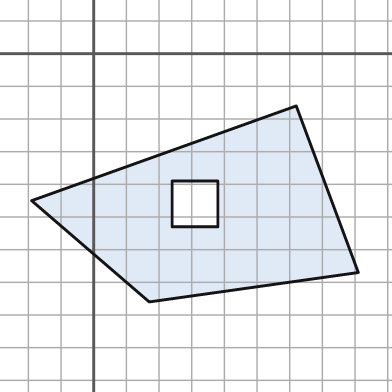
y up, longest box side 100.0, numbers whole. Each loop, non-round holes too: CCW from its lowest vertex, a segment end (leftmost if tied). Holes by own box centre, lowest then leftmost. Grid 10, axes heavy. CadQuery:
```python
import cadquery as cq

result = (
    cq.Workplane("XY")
    .moveTo(17.0, -76.0)
    .lineTo(81.0, -67.0)
    .lineTo(62.0, -16.0)
    .lineTo(-19.0, -45.0)
    .close()
    .moveTo(24.0, -53.0)
    .lineTo(38.0, -53.0)
    .lineTo(38.0, -39.0)
    .lineTo(24.0, -39.0)
    .close()
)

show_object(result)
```